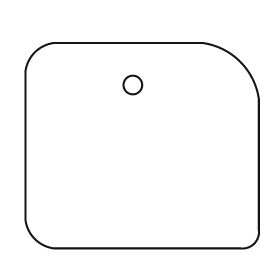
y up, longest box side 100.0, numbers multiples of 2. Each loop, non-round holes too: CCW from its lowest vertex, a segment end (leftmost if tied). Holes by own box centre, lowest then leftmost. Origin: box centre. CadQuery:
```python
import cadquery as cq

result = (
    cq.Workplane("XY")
    .moveTo(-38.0, -44.0)
    .lineTo(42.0, -44.0)
    .threePointArc((48.0, -42.0), (50.0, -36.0))
    .lineTo(50.0, 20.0)
    .threePointArc((42.0, 36.0), (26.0, 44.0))
    .lineTo(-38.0, 44.0)
    .threePointArc((-46.0, 40.0), (-50.0, 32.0))
    .lineTo(-50.0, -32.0)
    .threePointArc((-46.0, -40.0), (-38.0, -44.0))
    .close()
    .moveTo(-4.0, 26.0)
    .circle(4.0)
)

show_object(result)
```